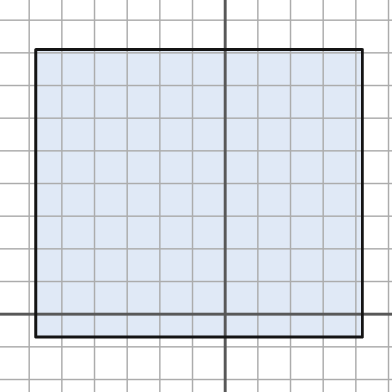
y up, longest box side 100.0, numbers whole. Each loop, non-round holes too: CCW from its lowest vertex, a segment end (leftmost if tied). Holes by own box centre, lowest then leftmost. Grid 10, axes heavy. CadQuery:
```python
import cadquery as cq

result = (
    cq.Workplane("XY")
    .moveTo(-58.0, -7.0)
    .lineTo(42.0, -7.0)
    .lineTo(42.0, 81.0)
    .lineTo(-58.0, 81.0)
    .close()
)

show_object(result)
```